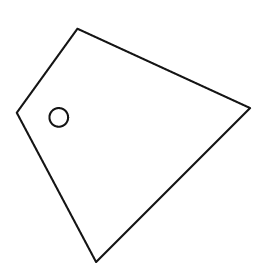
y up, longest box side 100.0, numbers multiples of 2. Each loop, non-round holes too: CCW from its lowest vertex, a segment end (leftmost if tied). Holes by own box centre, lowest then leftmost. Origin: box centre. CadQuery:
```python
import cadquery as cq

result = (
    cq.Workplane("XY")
    .moveTo(-16.0, -50.0)
    .lineTo(50.0, 16.0)
    .lineTo(-24.0, 50.0)
    .lineTo(-50.0, 14.0)
    .close()
    .moveTo(-32.0, 12.0)
    .circle(4.0)
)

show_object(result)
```